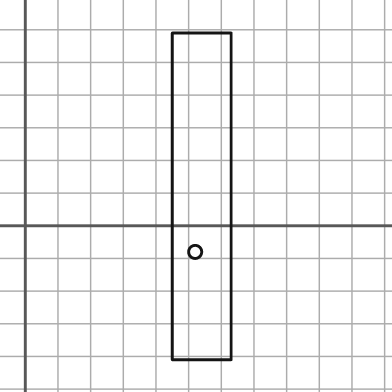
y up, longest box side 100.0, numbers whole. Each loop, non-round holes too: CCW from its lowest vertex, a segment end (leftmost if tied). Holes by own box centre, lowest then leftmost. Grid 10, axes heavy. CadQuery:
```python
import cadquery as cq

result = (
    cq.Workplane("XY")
    .moveTo(45.0, -41.0)
    .lineTo(63.0, -41.0)
    .lineTo(63.0, 59.0)
    .lineTo(45.0, 59.0)
    .close()
    .moveTo(52.0, -8.0)
    .circle(2.0)
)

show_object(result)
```